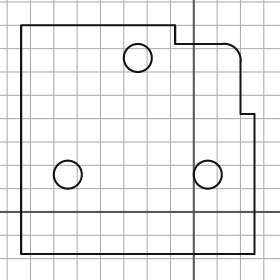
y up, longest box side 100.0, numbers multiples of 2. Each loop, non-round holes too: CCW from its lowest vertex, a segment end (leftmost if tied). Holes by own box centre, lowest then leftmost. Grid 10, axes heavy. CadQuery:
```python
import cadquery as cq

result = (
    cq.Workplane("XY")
    .moveTo(-74.0, -18.0)
    .lineTo(26.0, -18.0)
    .lineTo(26.0, 42.0)
    .lineTo(20.0, 42.0)
    .lineTo(20.0, 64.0)
    .threePointArc((18.0, 70.0), (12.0, 72.0))
    .lineTo(-8.0, 72.0)
    .lineTo(-8.0, 80.0)
    .lineTo(-74.0, 80.0)
    .close()
    .moveTo(-54.0, 16.0)
    .circle(6.0)
    .moveTo(6.0, 16.0)
    .circle(6.0)
    .moveTo(-24.0, 66.0)
    .circle(6.0)
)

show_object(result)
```